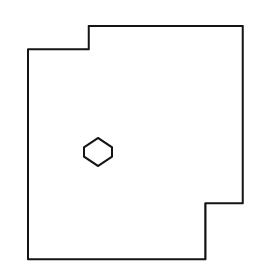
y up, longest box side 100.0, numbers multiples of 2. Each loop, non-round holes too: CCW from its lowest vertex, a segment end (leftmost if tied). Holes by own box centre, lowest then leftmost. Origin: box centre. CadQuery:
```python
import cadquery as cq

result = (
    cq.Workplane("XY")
    .moveTo(-46.0, -50.0)
    .lineTo(30.0, -50.0)
    .lineTo(30.0, -26.0)
    .lineTo(46.0, -26.0)
    .lineTo(46.0, 50.0)
    .lineTo(-20.0, 50.0)
    .lineTo(-20.0, 40.0)
    .lineTo(-46.0, 40.0)
    .close()
    .moveTo(-16.0, -10.0)
    .lineTo(-10.0, -6.0)
    .lineTo(-10.0, -2.0)
    .lineTo(-16.0, 2.0)
    .lineTo(-22.0, -2.0)
    .lineTo(-22.0, -6.0)
    .close()
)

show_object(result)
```